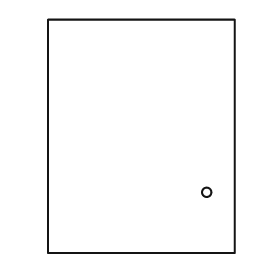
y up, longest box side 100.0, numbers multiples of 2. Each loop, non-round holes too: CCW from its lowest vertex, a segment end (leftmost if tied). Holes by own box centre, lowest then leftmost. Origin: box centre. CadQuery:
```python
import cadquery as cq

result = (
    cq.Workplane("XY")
    .moveTo(-40.0, -50.0)
    .lineTo(40.0, -50.0)
    .lineTo(40.0, 50.0)
    .lineTo(-40.0, 50.0)
    .close()
    .moveTo(28.0, -24.0)
    .circle(2.0)
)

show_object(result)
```